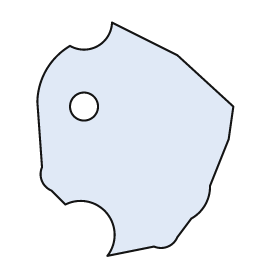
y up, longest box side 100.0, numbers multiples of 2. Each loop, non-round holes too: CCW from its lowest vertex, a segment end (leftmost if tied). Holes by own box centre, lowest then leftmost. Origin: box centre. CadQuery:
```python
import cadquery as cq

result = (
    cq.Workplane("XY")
    .moveTo(-12.0, -50.0)
    .lineTo(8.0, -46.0)
    .threePointArc((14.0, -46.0), (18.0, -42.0))
    .lineTo(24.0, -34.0)
    .threePointArc((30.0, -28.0), (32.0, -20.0))
    .lineTo(40.0, 0.0)
    .lineTo(42.0, 14.0)
    .lineTo(18.0, 36.0)
    .lineTo(-10.0, 50.0)
    .threePointArc((-16.0, 40.0), (-28.0, 40.0))
    .threePointArc((-38.0, 30.0), (-42.0, 16.0))
    .lineTo(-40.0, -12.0)
    .threePointArc((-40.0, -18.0), (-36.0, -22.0))
    .lineTo(-30.0, -28.0)
    .threePointArc((-12.0, -32.0), (-12.0, -50.0))
    .close()
    .moveTo(-22.0, 14.0)
    .circle(6.0)
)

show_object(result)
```